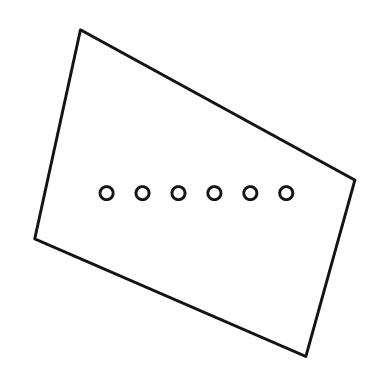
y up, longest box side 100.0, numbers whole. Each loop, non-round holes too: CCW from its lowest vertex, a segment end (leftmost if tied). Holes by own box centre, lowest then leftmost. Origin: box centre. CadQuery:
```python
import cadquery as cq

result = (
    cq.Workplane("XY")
    .moveTo(34.0, -50.0)
    .lineTo(49.0, 4.0)
    .lineTo(-35.0, 50.0)
    .lineTo(-49.0, -14.0)
    .close()
    .moveTo(-27.0, 0.0)
    .circle(2.0)
    .moveTo(-16.0, 0.0)
    .circle(2.0)
    .moveTo(-5.0, 0.0)
    .circle(2.0)
    .moveTo(6.0, 0.0)
    .circle(2.0)
    .moveTo(17.0, 0.0)
    .circle(2.0)
    .moveTo(28.0, 0.0)
    .circle(2.0)
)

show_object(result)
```